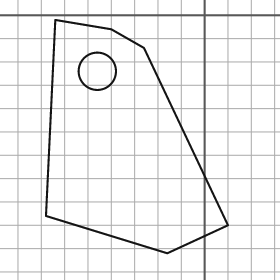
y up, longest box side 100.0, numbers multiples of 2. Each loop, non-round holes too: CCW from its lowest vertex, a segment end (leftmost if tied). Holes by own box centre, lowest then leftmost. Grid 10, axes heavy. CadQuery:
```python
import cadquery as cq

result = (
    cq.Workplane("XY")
    .moveTo(-16.0, -102.0)
    .lineTo(10.0, -90.0)
    .lineTo(-26.0, -14.0)
    .lineTo(-40.0, -6.0)
    .lineTo(-64.0, -2.0)
    .lineTo(-68.0, -86.0)
    .close()
    .moveTo(-46.0, -24.0)
    .circle(8.0)
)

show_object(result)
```